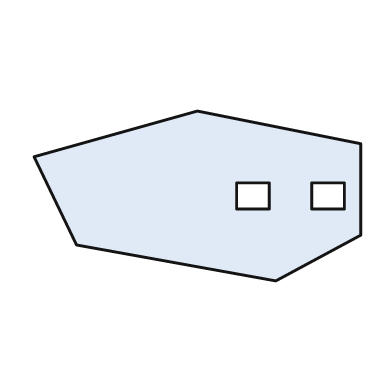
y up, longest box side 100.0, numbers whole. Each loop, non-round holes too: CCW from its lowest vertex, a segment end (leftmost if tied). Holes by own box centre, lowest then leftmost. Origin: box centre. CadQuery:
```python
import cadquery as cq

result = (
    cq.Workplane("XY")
    .moveTo(24.0, -26.0)
    .lineTo(50.0, -12.0)
    .lineTo(50.0, 16.0)
    .lineTo(0.0, 26.0)
    .lineTo(-50.0, 12.0)
    .lineTo(-37.0, -15.0)
    .close()
    .moveTo(12.0, -4.0)
    .lineTo(22.0, -4.0)
    .lineTo(22.0, 4.0)
    .lineTo(12.0, 4.0)
    .close()
    .moveTo(35.0, -4.0)
    .lineTo(45.0, -4.0)
    .lineTo(45.0, 4.0)
    .lineTo(35.0, 4.0)
    .close()
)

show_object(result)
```